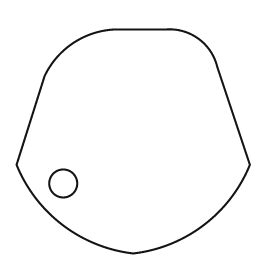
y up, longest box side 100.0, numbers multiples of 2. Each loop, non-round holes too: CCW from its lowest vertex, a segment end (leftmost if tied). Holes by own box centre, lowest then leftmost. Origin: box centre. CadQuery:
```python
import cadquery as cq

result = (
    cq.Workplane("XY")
    .moveTo(0.0, -48.0)
    .threePointArc((30.0, -36.0), (50.0, -10.0))
    .lineTo(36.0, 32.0)
    .threePointArc((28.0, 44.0), (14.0, 48.0))
    .lineTo(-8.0, 48.0)
    .threePointArc((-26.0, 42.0), (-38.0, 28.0))
    .lineTo(-50.0, -10.0)
    .threePointArc((-30.0, -36.0), (0.0, -48.0))
    .close()
    .moveTo(-30.0, -18.0)
    .circle(6.0)
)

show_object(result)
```